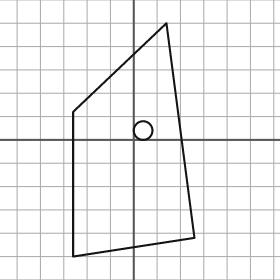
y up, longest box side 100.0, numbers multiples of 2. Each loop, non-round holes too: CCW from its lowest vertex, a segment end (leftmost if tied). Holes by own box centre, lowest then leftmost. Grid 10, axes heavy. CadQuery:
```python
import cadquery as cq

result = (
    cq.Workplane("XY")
    .moveTo(-26.0, -50.0)
    .lineTo(26.0, -42.0)
    .lineTo(14.0, 50.0)
    .lineTo(-26.0, 12.0)
    .close()
    .moveTo(4.0, 4.0)
    .circle(4.0)
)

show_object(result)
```